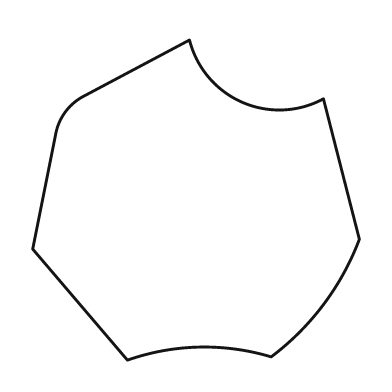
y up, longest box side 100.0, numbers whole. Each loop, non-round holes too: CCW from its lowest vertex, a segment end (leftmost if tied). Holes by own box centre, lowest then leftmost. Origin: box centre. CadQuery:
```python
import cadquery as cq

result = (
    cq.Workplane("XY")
    .moveTo(-21.0, -49.0)
    .threePointArc((1.0, -45.0), (23.0, -48.0))
    .threePointArc((39.0, -32.0), (50.0, -12.0))
    .lineTo(39.0, 31.0)
    .threePointArc((14.0, 30.0), (-2.0, 49.0))
    .lineTo(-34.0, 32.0)
    .threePointArc((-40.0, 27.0), (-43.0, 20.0))
    .lineTo(-50.0, -15.0)
    .close()
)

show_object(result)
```